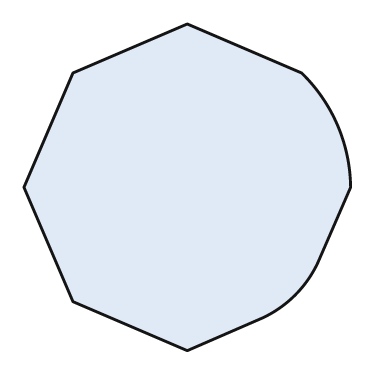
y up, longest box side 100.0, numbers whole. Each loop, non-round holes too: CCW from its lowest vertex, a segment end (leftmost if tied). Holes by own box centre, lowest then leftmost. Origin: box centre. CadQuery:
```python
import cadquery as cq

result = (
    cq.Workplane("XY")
    .moveTo(0.0, -50.0)
    .lineTo(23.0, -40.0)
    .threePointArc((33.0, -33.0), (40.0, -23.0))
    .lineTo(50.0, 0.0)
    .threePointArc((46.0, 19.0), (35.0, 35.0))
    .lineTo(0.0, 50.0)
    .lineTo(-35.0, 35.0)
    .lineTo(-50.0, 0.0)
    .lineTo(-35.0, -35.0)
    .close()
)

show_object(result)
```